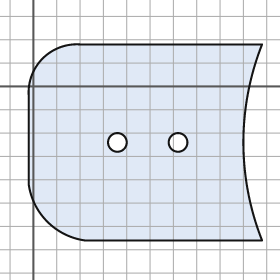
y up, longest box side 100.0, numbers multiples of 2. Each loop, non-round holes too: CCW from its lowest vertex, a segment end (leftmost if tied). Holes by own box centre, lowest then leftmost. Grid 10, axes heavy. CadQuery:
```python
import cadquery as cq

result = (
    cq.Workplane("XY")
    .moveTo(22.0, -66.0)
    .lineTo(98.0, -66.0)
    .threePointArc((90.0, -24.0), (98.0, 18.0))
    .lineTo(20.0, 18.0)
    .threePointArc((4.0, 12.0), (-2.0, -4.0))
    .lineTo(-2.0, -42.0)
    .threePointArc((6.0, -58.0), (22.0, -66.0))
    .close()
    .moveTo(36.0, -24.0)
    .circle(4.0)
    .moveTo(62.0, -24.0)
    .circle(4.0)
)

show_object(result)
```